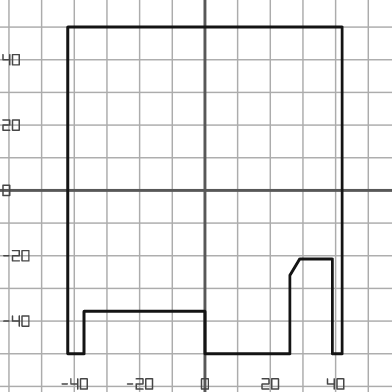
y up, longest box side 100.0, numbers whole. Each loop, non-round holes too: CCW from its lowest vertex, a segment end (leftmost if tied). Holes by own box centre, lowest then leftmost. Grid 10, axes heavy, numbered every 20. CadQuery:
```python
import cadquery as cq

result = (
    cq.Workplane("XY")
    .moveTo(-42.0, -50.0)
    .lineTo(-37.0, -50.0)
    .lineTo(-37.0, -37.0)
    .lineTo(0.0, -37.0)
    .lineTo(0.0, -50.0)
    .lineTo(26.0, -50.0)
    .lineTo(26.0, -26.0)
    .lineTo(29.0, -21.0)
    .lineTo(39.0, -21.0)
    .lineTo(39.0, -50.0)
    .lineTo(42.0, -50.0)
    .lineTo(42.0, 50.0)
    .lineTo(-42.0, 50.0)
    .close()
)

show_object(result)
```